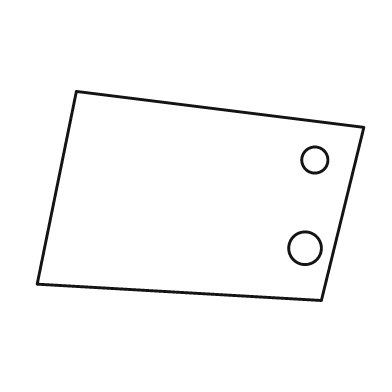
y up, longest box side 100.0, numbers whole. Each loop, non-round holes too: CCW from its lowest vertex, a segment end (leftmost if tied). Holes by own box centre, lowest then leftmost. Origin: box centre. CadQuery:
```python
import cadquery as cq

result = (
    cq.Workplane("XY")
    .moveTo(37.0, -32.0)
    .lineTo(50.0, 21.0)
    .lineTo(-38.0, 32.0)
    .lineTo(-50.0, -27.0)
    .close()
    .moveTo(32.0, -16.0)
    .circle(5.0)
    .moveTo(35.0, 11.0)
    .circle(4.0)
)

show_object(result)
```